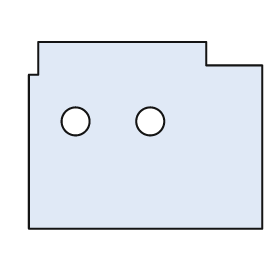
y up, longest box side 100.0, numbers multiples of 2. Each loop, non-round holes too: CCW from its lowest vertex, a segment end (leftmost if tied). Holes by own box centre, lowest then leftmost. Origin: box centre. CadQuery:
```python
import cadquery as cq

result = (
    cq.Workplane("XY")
    .moveTo(-50.0, -40.0)
    .lineTo(50.0, -40.0)
    .lineTo(50.0, 30.0)
    .lineTo(26.0, 30.0)
    .lineTo(26.0, 40.0)
    .lineTo(-46.0, 40.0)
    .lineTo(-46.0, 26.0)
    .lineTo(-50.0, 26.0)
    .close()
    .moveTo(-30.0, 6.0)
    .circle(6.0)
    .moveTo(2.0, 6.0)
    .circle(6.0)
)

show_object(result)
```